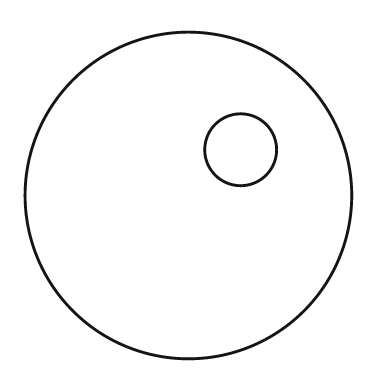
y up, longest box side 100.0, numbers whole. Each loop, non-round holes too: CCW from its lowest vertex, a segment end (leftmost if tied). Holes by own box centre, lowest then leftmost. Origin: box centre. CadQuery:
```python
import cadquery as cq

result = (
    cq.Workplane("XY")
    .moveTo(0.0, 0.0)
    .circle(50.0)
    .moveTo(16.0, 14.0)
    .circle(11.0)
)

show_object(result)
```